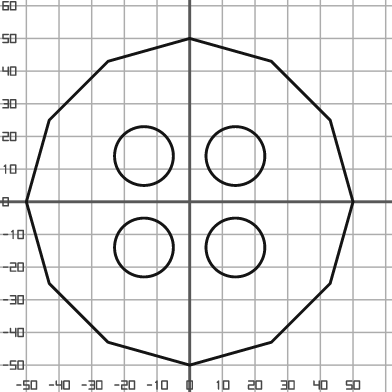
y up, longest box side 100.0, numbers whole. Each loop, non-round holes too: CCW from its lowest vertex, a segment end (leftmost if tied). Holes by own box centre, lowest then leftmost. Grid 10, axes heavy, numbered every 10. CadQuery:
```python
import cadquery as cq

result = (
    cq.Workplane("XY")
    .moveTo(0.0, -50.0)
    .lineTo(25.0, -43.0)
    .lineTo(43.0, -25.0)
    .lineTo(50.0, 0.0)
    .lineTo(43.0, 25.0)
    .lineTo(25.0, 43.0)
    .lineTo(0.0, 50.0)
    .lineTo(-25.0, 43.0)
    .lineTo(-43.0, 25.0)
    .lineTo(-50.0, 0.0)
    .lineTo(-43.0, -25.0)
    .lineTo(-25.0, -43.0)
    .close()
    .moveTo(-14.0, -14.0)
    .circle(9.0)
    .moveTo(14.0, -14.0)
    .circle(9.0)
    .moveTo(-14.0, 14.0)
    .circle(9.0)
    .moveTo(14.0, 14.0)
    .circle(9.0)
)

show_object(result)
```